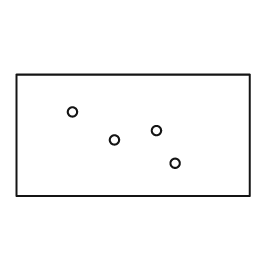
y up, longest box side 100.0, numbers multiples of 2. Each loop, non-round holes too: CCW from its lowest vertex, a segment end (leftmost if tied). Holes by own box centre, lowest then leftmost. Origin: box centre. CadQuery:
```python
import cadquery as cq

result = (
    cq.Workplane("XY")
    .moveTo(-50.0, -26.0)
    .lineTo(50.0, -26.0)
    .lineTo(50.0, 26.0)
    .lineTo(-50.0, 26.0)
    .close()
    .moveTo(18.0, -12.0)
    .circle(2.0)
    .moveTo(-8.0, -2.0)
    .circle(2.0)
    .moveTo(10.0, 2.0)
    .circle(2.0)
    .moveTo(-26.0, 10.0)
    .circle(2.0)
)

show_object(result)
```